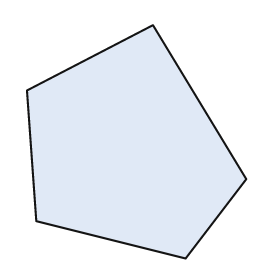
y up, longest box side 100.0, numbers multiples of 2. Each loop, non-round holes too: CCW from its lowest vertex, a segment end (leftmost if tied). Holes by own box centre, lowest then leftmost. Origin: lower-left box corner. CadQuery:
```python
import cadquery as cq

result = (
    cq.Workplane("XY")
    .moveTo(68.0, 0.0)
    .lineTo(94.0, 34.0)
    .lineTo(54.0, 100.0)
    .lineTo(0.0, 72.0)
    .lineTo(4.0, 16.0)
    .close()
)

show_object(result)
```